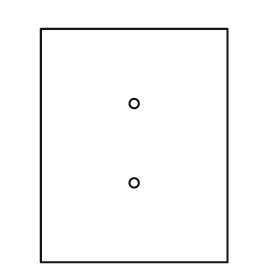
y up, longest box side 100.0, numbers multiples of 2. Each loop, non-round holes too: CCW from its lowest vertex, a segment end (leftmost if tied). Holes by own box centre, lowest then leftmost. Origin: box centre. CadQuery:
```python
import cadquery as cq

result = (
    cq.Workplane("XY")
    .moveTo(-40.0, -50.0)
    .lineTo(40.0, -50.0)
    .lineTo(40.0, 50.0)
    .lineTo(-40.0, 50.0)
    .close()
    .moveTo(0.0, -16.0)
    .circle(2.0)
    .moveTo(0.0, 18.0)
    .circle(2.0)
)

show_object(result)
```